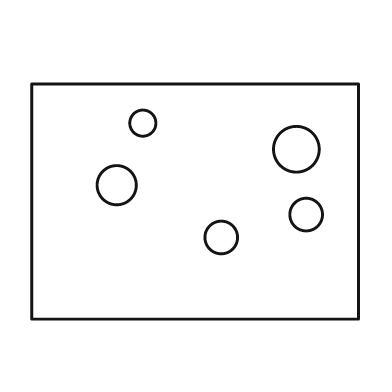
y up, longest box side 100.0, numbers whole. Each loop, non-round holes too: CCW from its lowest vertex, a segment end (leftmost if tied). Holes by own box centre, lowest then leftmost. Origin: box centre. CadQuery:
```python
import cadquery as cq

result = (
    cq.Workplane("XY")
    .moveTo(-50.0, -36.0)
    .lineTo(50.0, -36.0)
    .lineTo(50.0, 36.0)
    .lineTo(-50.0, 36.0)
    .close()
    .moveTo(8.0, -11.0)
    .circle(5.0)
    .moveTo(34.0, -4.0)
    .circle(5.0)
    .moveTo(-24.0, 5.0)
    .circle(6.0)
    .moveTo(31.0, 16.0)
    .circle(7.0)
    .moveTo(-16.0, 24.0)
    .circle(4.0)
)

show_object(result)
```